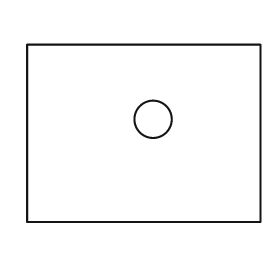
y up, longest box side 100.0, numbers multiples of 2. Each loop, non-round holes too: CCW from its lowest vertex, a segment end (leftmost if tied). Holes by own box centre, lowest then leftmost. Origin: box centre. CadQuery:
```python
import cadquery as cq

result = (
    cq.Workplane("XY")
    .moveTo(-50.0, -38.0)
    .lineTo(50.0, -38.0)
    .lineTo(50.0, 38.0)
    .lineTo(-50.0, 38.0)
    .close()
    .moveTo(4.0, 6.0)
    .circle(8.0)
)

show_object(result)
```